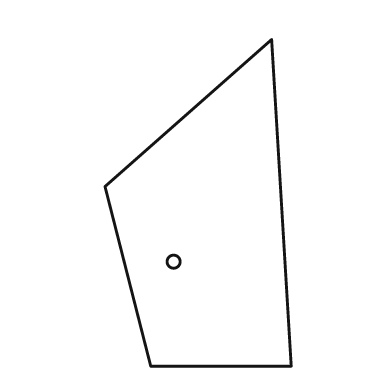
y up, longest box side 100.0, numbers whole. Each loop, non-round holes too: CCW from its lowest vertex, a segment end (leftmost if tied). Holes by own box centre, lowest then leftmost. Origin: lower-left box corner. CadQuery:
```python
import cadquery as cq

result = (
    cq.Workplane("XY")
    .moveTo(14.0, 0.0)
    .lineTo(57.0, 0.0)
    .lineTo(51.0, 100.0)
    .lineTo(0.0, 55.0)
    .close()
    .moveTo(21.0, 32.0)
    .circle(2.0)
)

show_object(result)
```